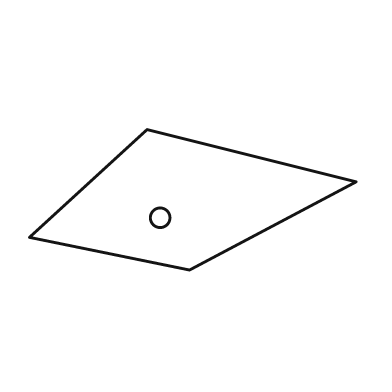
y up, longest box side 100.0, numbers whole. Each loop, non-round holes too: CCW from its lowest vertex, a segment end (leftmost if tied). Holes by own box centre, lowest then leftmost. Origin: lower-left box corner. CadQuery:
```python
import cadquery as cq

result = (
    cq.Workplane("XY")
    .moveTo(49.0, 0.0)
    .lineTo(100.0, 27.0)
    .lineTo(36.0, 43.0)
    .lineTo(0.0, 10.0)
    .close()
    .moveTo(40.0, 16.0)
    .circle(3.0)
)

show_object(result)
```